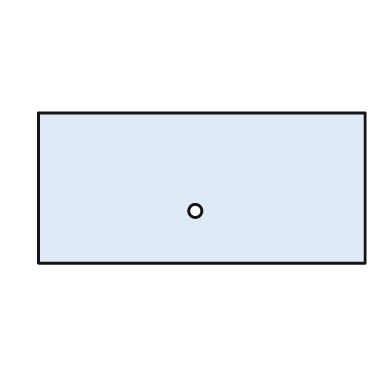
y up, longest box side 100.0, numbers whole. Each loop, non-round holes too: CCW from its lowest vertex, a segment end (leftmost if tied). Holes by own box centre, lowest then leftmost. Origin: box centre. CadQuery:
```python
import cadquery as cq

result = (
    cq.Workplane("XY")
    .moveTo(-50.0, -23.0)
    .lineTo(50.0, -23.0)
    .lineTo(50.0, 23.0)
    .lineTo(-50.0, 23.0)
    .close()
    .moveTo(-2.0, -7.0)
    .circle(2.0)
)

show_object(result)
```